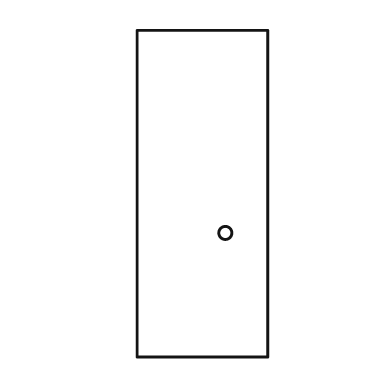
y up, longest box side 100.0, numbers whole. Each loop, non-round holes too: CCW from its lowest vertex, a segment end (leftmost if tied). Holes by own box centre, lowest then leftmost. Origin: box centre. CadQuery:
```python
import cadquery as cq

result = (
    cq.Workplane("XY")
    .moveTo(-20.0, -50.0)
    .lineTo(20.0, -50.0)
    .lineTo(20.0, 50.0)
    .lineTo(-20.0, 50.0)
    .close()
    .moveTo(7.0, -12.0)
    .circle(2.0)
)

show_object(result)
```